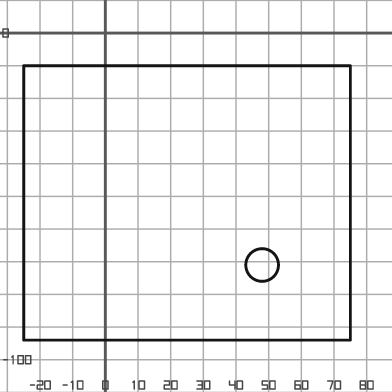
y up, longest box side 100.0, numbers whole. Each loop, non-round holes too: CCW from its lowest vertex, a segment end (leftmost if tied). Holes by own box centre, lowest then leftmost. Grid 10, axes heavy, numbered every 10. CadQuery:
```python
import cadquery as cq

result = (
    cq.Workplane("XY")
    .moveTo(-25.0, -94.0)
    .lineTo(75.0, -94.0)
    .lineTo(75.0, -10.0)
    .lineTo(-25.0, -10.0)
    .close()
    .moveTo(48.0, -71.0)
    .circle(5.0)
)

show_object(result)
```